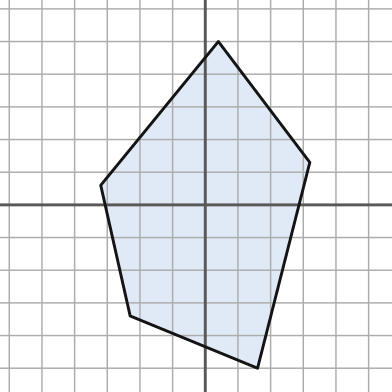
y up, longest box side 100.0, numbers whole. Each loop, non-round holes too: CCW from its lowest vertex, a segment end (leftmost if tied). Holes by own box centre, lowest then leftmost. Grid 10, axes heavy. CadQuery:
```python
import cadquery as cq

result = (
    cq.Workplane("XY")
    .moveTo(16.0, -50.0)
    .lineTo(32.0, 13.0)
    .lineTo(4.0, 50.0)
    .lineTo(-32.0, 6.0)
    .lineTo(-23.0, -34.0)
    .close()
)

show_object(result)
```